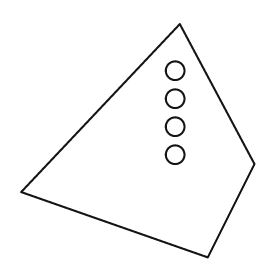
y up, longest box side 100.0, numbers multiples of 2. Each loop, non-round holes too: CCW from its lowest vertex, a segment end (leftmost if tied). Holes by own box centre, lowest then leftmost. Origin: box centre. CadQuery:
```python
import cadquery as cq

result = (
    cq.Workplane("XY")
    .moveTo(30.0, -50.0)
    .lineTo(50.0, -10.0)
    .lineTo(18.0, 50.0)
    .lineTo(-50.0, -22.0)
    .close()
    .moveTo(16.0, -6.0)
    .circle(4.0)
    .moveTo(16.0, 6.0)
    .circle(4.0)
    .moveTo(16.0, 18.0)
    .circle(4.0)
    .moveTo(16.0, 30.0)
    .circle(4.0)
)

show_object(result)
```